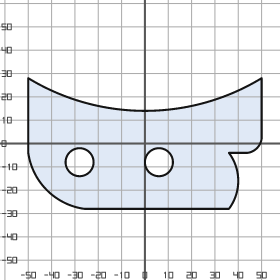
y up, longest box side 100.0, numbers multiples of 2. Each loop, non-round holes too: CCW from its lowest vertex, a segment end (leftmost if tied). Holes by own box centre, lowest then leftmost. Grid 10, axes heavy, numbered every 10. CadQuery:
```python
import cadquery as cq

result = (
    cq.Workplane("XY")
    .moveTo(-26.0, -28.0)
    .lineTo(36.0, -28.0)
    .threePointArc((40.0, -16.0), (36.0, -4.0))
    .lineTo(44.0, -4.0)
    .threePointArc((48.0, -2.0), (50.0, 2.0))
    .lineTo(50.0, 28.0)
    .threePointArc((0.0, 14.0), (-50.0, 28.0))
    .lineTo(-50.0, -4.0)
    .threePointArc((-42.0, -20.0), (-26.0, -28.0))
    .close()
    .moveTo(-28.0, -8.0)
    .circle(6.0)
    .moveTo(6.0, -8.0)
    .circle(6.0)
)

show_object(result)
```